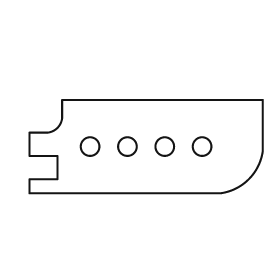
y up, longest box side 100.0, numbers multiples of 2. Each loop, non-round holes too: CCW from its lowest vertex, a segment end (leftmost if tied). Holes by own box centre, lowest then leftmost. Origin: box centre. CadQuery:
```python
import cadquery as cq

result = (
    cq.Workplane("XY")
    .moveTo(-50.0, -20.0)
    .lineTo(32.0, -20.0)
    .threePointArc((44.0, -14.0), (50.0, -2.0))
    .lineTo(50.0, 20.0)
    .lineTo(-36.0, 20.0)
    .lineTo(-36.0, 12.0)
    .threePointArc((-38.0, 8.0), (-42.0, 6.0))
    .lineTo(-50.0, 6.0)
    .lineTo(-50.0, -4.0)
    .lineTo(-38.0, -4.0)
    .lineTo(-38.0, -14.0)
    .lineTo(-50.0, -14.0)
    .close()
    .moveTo(-24.0, 0.0)
    .circle(4.0)
    .moveTo(-8.0, 0.0)
    .circle(4.0)
    .moveTo(8.0, 0.0)
    .circle(4.0)
    .moveTo(24.0, 0.0)
    .circle(4.0)
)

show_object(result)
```